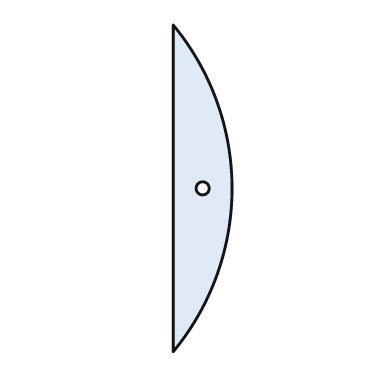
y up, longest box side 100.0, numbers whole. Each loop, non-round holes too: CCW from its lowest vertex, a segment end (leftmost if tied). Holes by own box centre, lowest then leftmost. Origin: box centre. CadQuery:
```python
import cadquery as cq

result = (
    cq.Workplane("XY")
    .moveTo(-9.0, -50.0)
    .threePointArc((9.0, 0.0), (-9.0, 50.0))
    .close()
    .moveTo(0.0, 0.0)
    .circle(2.0)
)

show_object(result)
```